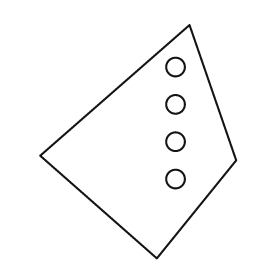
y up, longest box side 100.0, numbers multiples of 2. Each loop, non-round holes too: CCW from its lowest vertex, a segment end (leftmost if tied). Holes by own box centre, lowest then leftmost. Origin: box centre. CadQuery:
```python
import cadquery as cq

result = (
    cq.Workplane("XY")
    .moveTo(8.0, -50.0)
    .lineTo(42.0, -8.0)
    .lineTo(22.0, 50.0)
    .lineTo(-42.0, -6.0)
    .close()
    .moveTo(16.0, -16.0)
    .circle(4.0)
    .moveTo(16.0, 0.0)
    .circle(4.0)
    .moveTo(16.0, 16.0)
    .circle(4.0)
    .moveTo(16.0, 32.0)
    .circle(4.0)
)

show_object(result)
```